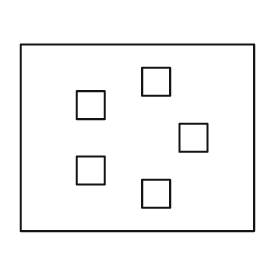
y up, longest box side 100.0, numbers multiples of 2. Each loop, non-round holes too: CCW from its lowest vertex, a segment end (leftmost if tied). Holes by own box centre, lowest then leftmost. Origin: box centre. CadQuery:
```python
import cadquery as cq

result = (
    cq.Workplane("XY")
    .moveTo(-50.0, -40.0)
    .lineTo(50.0, -40.0)
    .lineTo(50.0, 40.0)
    .lineTo(-50.0, 40.0)
    .close()
    .moveTo(2.0, -30.0)
    .lineTo(14.0, -30.0)
    .lineTo(14.0, -18.0)
    .lineTo(2.0, -18.0)
    .close()
    .moveTo(-26.0, -20.0)
    .lineTo(-14.0, -20.0)
    .lineTo(-14.0, -8.0)
    .lineTo(-26.0, -8.0)
    .close()
    .moveTo(18.0, -6.0)
    .lineTo(30.0, -6.0)
    .lineTo(30.0, 6.0)
    .lineTo(18.0, 6.0)
    .close()
    .moveTo(-26.0, 8.0)
    .lineTo(-14.0, 8.0)
    .lineTo(-14.0, 20.0)
    .lineTo(-26.0, 20.0)
    .close()
    .moveTo(2.0, 18.0)
    .lineTo(14.0, 18.0)
    .lineTo(14.0, 30.0)
    .lineTo(2.0, 30.0)
    .close()
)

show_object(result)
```